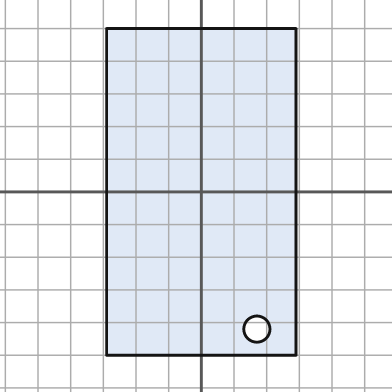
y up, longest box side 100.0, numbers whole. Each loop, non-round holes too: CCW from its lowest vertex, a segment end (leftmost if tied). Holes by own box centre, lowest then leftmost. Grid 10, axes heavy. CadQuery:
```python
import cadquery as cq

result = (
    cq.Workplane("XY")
    .moveTo(-29.0, -50.0)
    .lineTo(29.0, -50.0)
    .lineTo(29.0, 50.0)
    .lineTo(-29.0, 50.0)
    .close()
    .moveTo(17.0, -42.0)
    .circle(4.0)
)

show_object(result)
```